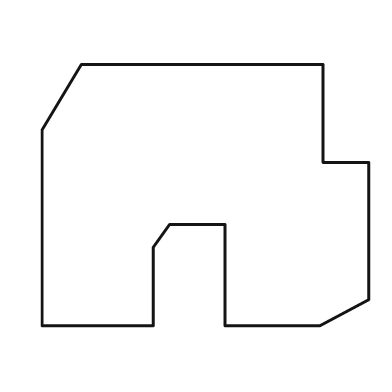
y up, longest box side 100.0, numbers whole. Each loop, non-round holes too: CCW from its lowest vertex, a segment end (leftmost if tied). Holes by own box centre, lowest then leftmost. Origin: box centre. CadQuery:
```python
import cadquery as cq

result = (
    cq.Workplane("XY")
    .moveTo(-50.0, -40.0)
    .lineTo(-16.0, -40.0)
    .lineTo(-16.0, -16.0)
    .lineTo(-11.0, -9.0)
    .lineTo(6.0, -9.0)
    .lineTo(6.0, -40.0)
    .lineTo(35.0, -40.0)
    .lineTo(50.0, -32.0)
    .lineTo(50.0, 10.0)
    .lineTo(36.0, 10.0)
    .lineTo(36.0, 40.0)
    .lineTo(-38.0, 40.0)
    .lineTo(-50.0, 20.0)
    .close()
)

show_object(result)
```